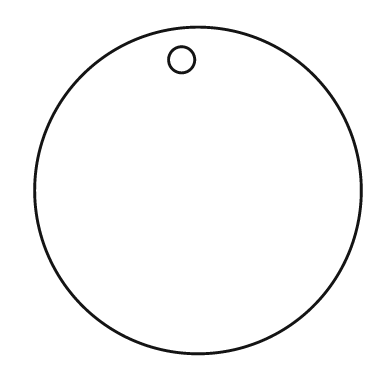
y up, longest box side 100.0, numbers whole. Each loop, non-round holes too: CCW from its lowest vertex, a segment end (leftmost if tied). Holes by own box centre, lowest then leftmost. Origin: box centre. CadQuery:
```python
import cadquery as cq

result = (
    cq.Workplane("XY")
    .moveTo(0.0, 0.0)
    .circle(50.0)
    .moveTo(-5.0, 40.0)
    .circle(4.0)
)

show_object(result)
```